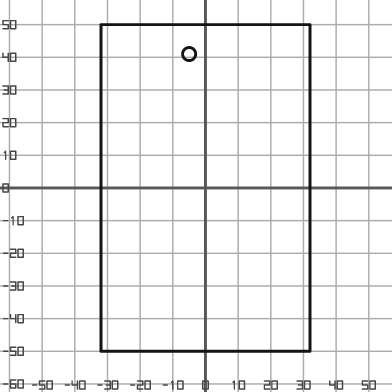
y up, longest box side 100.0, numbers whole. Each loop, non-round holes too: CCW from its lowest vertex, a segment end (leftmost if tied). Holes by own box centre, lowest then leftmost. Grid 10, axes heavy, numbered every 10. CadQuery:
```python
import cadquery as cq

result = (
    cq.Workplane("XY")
    .moveTo(-32.0, -50.0)
    .lineTo(32.0, -50.0)
    .lineTo(32.0, 50.0)
    .lineTo(-32.0, 50.0)
    .close()
    .moveTo(-5.0, 41.0)
    .circle(2.0)
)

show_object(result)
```